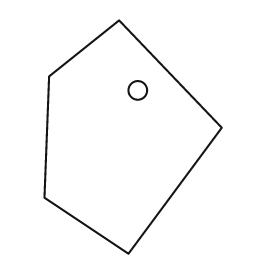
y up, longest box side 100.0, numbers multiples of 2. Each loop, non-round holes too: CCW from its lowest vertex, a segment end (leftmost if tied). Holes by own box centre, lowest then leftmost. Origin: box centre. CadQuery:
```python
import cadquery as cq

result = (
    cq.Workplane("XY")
    .moveTo(-2.0, -50.0)
    .lineTo(38.0, 4.0)
    .lineTo(-6.0, 50.0)
    .lineTo(-36.0, 26.0)
    .lineTo(-38.0, -26.0)
    .close()
    .moveTo(2.0, 20.0)
    .circle(4.0)
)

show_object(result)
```